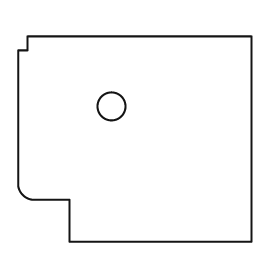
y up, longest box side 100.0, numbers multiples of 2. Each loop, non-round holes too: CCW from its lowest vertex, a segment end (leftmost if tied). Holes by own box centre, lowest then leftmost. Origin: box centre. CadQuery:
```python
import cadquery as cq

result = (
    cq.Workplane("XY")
    .moveTo(-28.0, -44.0)
    .lineTo(50.0, -44.0)
    .lineTo(50.0, 44.0)
    .lineTo(-46.0, 44.0)
    .lineTo(-46.0, 38.0)
    .lineTo(-50.0, 38.0)
    .lineTo(-50.0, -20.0)
    .threePointArc((-48.0, -24.0), (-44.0, -26.0))
    .lineTo(-28.0, -26.0)
    .close()
    .moveTo(-10.0, 14.0)
    .circle(6.0)
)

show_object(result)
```